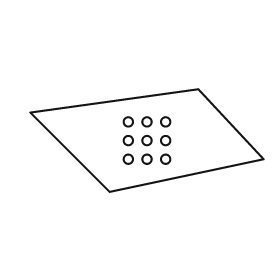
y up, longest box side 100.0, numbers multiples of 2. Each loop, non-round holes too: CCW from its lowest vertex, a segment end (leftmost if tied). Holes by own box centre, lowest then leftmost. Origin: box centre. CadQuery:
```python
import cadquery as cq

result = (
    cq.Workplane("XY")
    .moveTo(-16.0, -22.0)
    .lineTo(50.0, -8.0)
    .lineTo(22.0, 22.0)
    .lineTo(-50.0, 12.0)
    .close()
    .moveTo(-8.0, -8.0)
    .circle(2.0)
    .moveTo(0.0, -8.0)
    .circle(2.0)
    .moveTo(8.0, -8.0)
    .circle(2.0)
    .moveTo(-8.0, 0.0)
    .circle(2.0)
    .moveTo(0.0, 0.0)
    .circle(2.0)
    .moveTo(8.0, 0.0)
    .circle(2.0)
    .moveTo(-8.0, 8.0)
    .circle(2.0)
    .moveTo(0.0, 8.0)
    .circle(2.0)
    .moveTo(8.0, 8.0)
    .circle(2.0)
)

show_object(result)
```